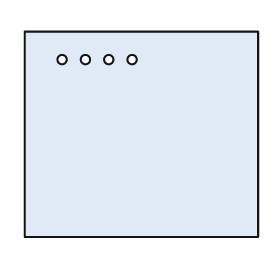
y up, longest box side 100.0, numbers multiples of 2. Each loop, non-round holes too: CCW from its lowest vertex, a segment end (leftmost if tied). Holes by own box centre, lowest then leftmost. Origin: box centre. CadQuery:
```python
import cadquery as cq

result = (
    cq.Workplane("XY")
    .moveTo(-50.0, -44.0)
    .lineTo(50.0, -44.0)
    .lineTo(50.0, 44.0)
    .lineTo(-50.0, 44.0)
    .close()
    .moveTo(-34.0, 32.0)
    .circle(2.0)
    .moveTo(-24.0, 32.0)
    .circle(2.0)
    .moveTo(-14.0, 32.0)
    .circle(2.0)
    .moveTo(-4.0, 32.0)
    .circle(2.0)
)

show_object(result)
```